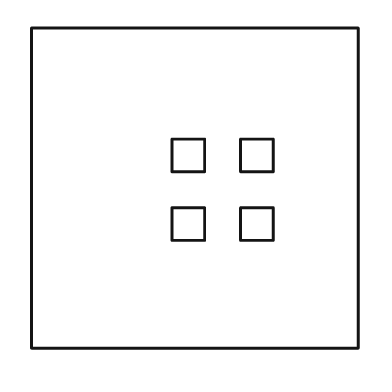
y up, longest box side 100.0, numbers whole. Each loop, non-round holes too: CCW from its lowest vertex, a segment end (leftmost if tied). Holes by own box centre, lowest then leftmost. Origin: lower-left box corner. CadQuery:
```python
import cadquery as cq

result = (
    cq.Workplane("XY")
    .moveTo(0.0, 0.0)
    .lineTo(100.0, 0.0)
    .lineTo(100.0, 98.0)
    .lineTo(0.0, 98.0)
    .close()
    .moveTo(43.0, 33.0)
    .lineTo(53.0, 33.0)
    .lineTo(53.0, 43.0)
    .lineTo(43.0, 43.0)
    .close()
    .moveTo(64.0, 33.0)
    .lineTo(74.0, 33.0)
    .lineTo(74.0, 43.0)
    .lineTo(64.0, 43.0)
    .close()
    .moveTo(43.0, 54.0)
    .lineTo(53.0, 54.0)
    .lineTo(53.0, 64.0)
    .lineTo(43.0, 64.0)
    .close()
    .moveTo(64.0, 54.0)
    .lineTo(74.0, 54.0)
    .lineTo(74.0, 64.0)
    .lineTo(64.0, 64.0)
    .close()
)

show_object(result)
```